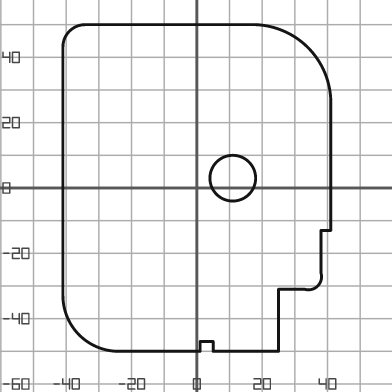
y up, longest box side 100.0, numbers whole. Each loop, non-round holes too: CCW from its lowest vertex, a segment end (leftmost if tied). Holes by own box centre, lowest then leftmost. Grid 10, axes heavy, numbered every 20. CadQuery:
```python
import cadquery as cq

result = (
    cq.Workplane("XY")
    .moveTo(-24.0, -50.0)
    .lineTo(1.0, -50.0)
    .lineTo(1.0, -47.0)
    .lineTo(5.0, -47.0)
    .lineTo(5.0, -50.0)
    .lineTo(25.0, -50.0)
    .lineTo(25.0, -31.0)
    .lineTo(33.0, -31.0)
    .threePointArc((37.0, -30.0), (38.0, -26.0))
    .lineTo(38.0, -13.0)
    .lineTo(41.0, -13.0)
    .lineTo(41.0, 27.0)
    .threePointArc((34.0, 43.0), (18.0, 50.0))
    .lineTo(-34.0, 50.0)
    .threePointArc((-39.0, 48.0), (-41.0, 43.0))
    .lineTo(-41.0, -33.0)
    .threePointArc((-36.0, -45.0), (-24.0, -50.0))
    .close()
    .moveTo(11.0, 3.0)
    .circle(7.0)
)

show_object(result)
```